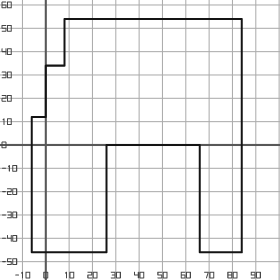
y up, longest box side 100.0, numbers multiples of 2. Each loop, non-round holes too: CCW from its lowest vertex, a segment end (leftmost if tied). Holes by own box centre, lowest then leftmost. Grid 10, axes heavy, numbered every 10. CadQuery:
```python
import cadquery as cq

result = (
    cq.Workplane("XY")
    .moveTo(-6.0, -46.0)
    .lineTo(26.0, -46.0)
    .lineTo(26.0, 0.0)
    .lineTo(66.0, 0.0)
    .lineTo(66.0, -46.0)
    .lineTo(84.0, -46.0)
    .lineTo(84.0, 54.0)
    .lineTo(8.0, 54.0)
    .lineTo(8.0, 34.0)
    .lineTo(0.0, 34.0)
    .lineTo(0.0, 12.0)
    .lineTo(-6.0, 12.0)
    .close()
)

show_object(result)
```